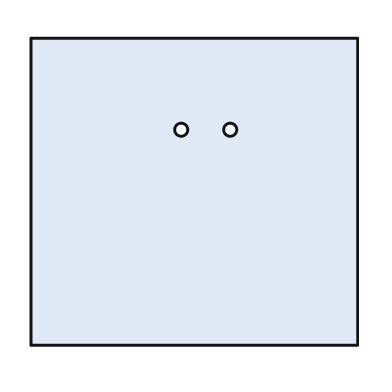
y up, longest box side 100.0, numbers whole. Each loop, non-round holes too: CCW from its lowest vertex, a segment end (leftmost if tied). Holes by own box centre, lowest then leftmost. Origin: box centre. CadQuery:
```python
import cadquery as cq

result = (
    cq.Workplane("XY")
    .moveTo(-50.0, -47.0)
    .lineTo(50.0, -47.0)
    .lineTo(50.0, 47.0)
    .lineTo(-50.0, 47.0)
    .close()
    .moveTo(-4.0, 19.0)
    .circle(2.0)
    .moveTo(11.0, 19.0)
    .circle(2.0)
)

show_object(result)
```